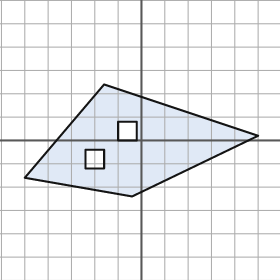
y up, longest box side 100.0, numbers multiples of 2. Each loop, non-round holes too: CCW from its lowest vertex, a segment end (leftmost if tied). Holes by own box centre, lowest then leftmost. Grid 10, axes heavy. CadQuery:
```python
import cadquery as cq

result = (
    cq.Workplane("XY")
    .moveTo(-4.0, -24.0)
    .lineTo(50.0, 2.0)
    .lineTo(-16.0, 24.0)
    .lineTo(-50.0, -16.0)
    .close()
    .moveTo(-24.0, -12.0)
    .lineTo(-16.0, -12.0)
    .lineTo(-16.0, -4.0)
    .lineTo(-24.0, -4.0)
    .close()
    .moveTo(-10.0, 0.0)
    .lineTo(-2.0, 0.0)
    .lineTo(-2.0, 8.0)
    .lineTo(-10.0, 8.0)
    .close()
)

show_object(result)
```